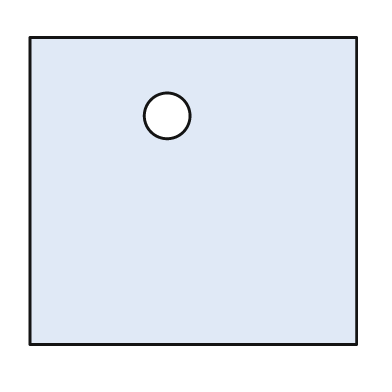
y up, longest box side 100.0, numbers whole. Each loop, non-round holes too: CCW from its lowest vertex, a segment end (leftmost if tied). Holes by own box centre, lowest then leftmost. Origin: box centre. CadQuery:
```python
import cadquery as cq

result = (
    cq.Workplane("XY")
    .moveTo(-50.0, -47.0)
    .lineTo(50.0, -47.0)
    .lineTo(50.0, 47.0)
    .lineTo(-50.0, 47.0)
    .close()
    .moveTo(-8.0, 23.0)
    .circle(7.0)
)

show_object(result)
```